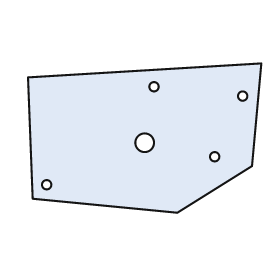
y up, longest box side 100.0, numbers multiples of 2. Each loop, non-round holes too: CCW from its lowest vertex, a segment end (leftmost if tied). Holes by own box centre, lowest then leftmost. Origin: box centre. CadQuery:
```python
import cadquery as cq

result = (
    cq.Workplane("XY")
    .moveTo(14.0, -32.0)
    .lineTo(46.0, -12.0)
    .lineTo(50.0, 32.0)
    .lineTo(-50.0, 26.0)
    .lineTo(-48.0, -26.0)
    .close()
    .moveTo(-42.0, -20.0)
    .circle(2.0)
    .moveTo(30.0, -8.0)
    .circle(2.0)
    .moveTo(0.0, -2.0)
    .circle(4.0)
    .moveTo(42.0, 18.0)
    .circle(2.0)
    .moveTo(4.0, 22.0)
    .circle(2.0)
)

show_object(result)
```